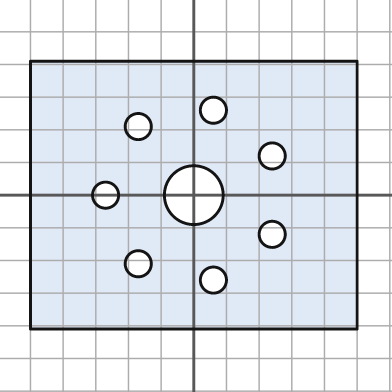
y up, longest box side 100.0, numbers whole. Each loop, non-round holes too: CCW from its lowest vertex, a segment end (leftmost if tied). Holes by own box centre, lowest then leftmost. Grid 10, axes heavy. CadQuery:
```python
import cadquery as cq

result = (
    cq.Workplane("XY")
    .moveTo(-50.0, -41.0)
    .lineTo(50.0, -41.0)
    .lineTo(50.0, 41.0)
    .lineTo(-50.0, 41.0)
    .close()
    .moveTo(6.0, -26.0)
    .circle(4.0)
    .moveTo(-17.0, -21.0)
    .circle(4.0)
    .moveTo(24.0, -12.0)
    .circle(4.0)
    .moveTo(-27.0, 0.0)
    .circle(4.0)
    .moveTo(0.0, 0.0)
    .circle(9.0)
    .moveTo(24.0, 12.0)
    .circle(4.0)
    .moveTo(-17.0, 21.0)
    .circle(4.0)
    .moveTo(6.0, 26.0)
    .circle(4.0)
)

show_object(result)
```